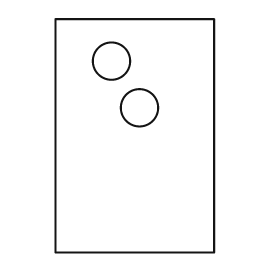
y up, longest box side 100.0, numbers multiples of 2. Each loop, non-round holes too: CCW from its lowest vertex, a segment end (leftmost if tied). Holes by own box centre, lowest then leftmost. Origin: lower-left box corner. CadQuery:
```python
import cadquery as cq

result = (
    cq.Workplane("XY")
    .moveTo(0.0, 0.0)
    .lineTo(68.0, 0.0)
    .lineTo(68.0, 100.0)
    .lineTo(0.0, 100.0)
    .close()
    .moveTo(36.0, 62.0)
    .circle(8.0)
    .moveTo(24.0, 82.0)
    .circle(8.0)
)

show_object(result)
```